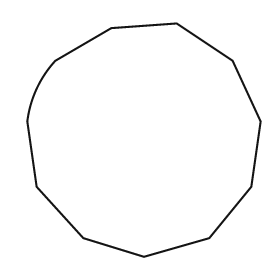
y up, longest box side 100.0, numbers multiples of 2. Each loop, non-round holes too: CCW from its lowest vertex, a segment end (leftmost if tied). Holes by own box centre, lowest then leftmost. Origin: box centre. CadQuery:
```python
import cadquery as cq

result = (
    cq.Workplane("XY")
    .moveTo(0.0, -50.0)
    .lineTo(28.0, -42.0)
    .lineTo(46.0, -20.0)
    .lineTo(50.0, 8.0)
    .lineTo(38.0, 34.0)
    .lineTo(14.0, 50.0)
    .lineTo(-14.0, 48.0)
    .lineTo(-38.0, 34.0)
    .threePointArc((-46.0, 22.0), (-50.0, 8.0))
    .lineTo(-46.0, -20.0)
    .lineTo(-26.0, -42.0)
    .close()
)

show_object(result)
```